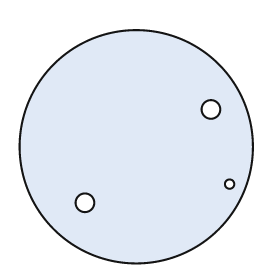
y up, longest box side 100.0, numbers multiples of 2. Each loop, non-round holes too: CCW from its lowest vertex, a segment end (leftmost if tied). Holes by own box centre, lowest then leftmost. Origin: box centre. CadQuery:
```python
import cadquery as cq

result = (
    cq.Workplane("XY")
    .moveTo(0.0, 0.0)
    .circle(50.0)
    .moveTo(-22.0, -24.0)
    .circle(4.0)
    .moveTo(40.0, -16.0)
    .circle(2.0)
    .moveTo(32.0, 16.0)
    .circle(4.0)
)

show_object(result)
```